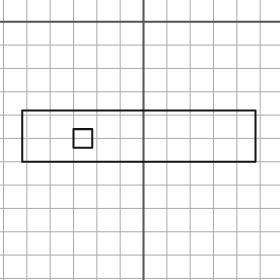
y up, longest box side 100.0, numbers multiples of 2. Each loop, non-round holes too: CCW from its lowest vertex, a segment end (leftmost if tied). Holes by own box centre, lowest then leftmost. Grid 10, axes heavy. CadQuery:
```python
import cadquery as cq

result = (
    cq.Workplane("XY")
    .moveTo(-52.0, -60.0)
    .lineTo(48.0, -60.0)
    .lineTo(48.0, -38.0)
    .lineTo(-52.0, -38.0)
    .close()
    .moveTo(-30.0, -54.0)
    .lineTo(-22.0, -54.0)
    .lineTo(-22.0, -46.0)
    .lineTo(-30.0, -46.0)
    .close()
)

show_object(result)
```